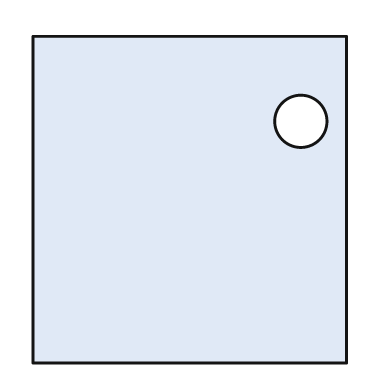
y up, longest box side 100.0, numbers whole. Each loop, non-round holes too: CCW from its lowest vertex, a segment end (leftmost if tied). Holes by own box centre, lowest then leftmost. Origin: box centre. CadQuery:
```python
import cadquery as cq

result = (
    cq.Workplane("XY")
    .moveTo(-48.0, -50.0)
    .lineTo(48.0, -50.0)
    .lineTo(48.0, 50.0)
    .lineTo(-48.0, 50.0)
    .close()
    .moveTo(34.0, 24.0)
    .circle(8.0)
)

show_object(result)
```